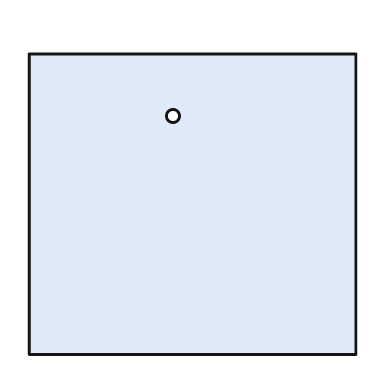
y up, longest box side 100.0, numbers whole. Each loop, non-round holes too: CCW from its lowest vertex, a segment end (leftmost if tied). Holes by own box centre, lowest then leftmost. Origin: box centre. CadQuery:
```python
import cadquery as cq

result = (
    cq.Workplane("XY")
    .moveTo(-50.0, -46.0)
    .lineTo(50.0, -46.0)
    .lineTo(50.0, 46.0)
    .lineTo(-50.0, 46.0)
    .close()
    .moveTo(-6.0, 27.0)
    .circle(2.0)
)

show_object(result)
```